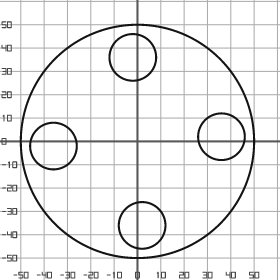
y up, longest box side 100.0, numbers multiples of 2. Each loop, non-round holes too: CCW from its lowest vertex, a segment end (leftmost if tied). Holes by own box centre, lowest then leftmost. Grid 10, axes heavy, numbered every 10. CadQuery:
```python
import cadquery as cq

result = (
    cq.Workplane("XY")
    .moveTo(0.0, 0.0)
    .circle(50.0)
    .moveTo(2.0, -36.0)
    .circle(10.0)
    .moveTo(-36.0, -2.0)
    .circle(10.0)
    .moveTo(36.0, 2.0)
    .circle(10.0)
    .moveTo(-2.0, 36.0)
    .circle(10.0)
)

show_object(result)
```